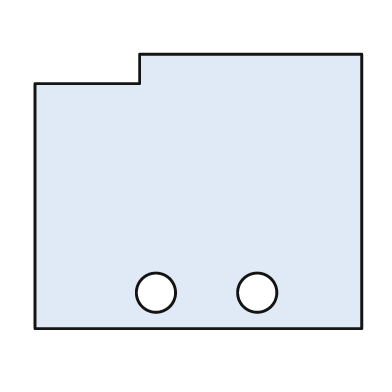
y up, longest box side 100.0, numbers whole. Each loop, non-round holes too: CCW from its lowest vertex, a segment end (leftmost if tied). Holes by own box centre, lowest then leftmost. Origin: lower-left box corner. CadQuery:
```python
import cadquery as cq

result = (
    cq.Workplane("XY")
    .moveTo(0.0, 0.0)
    .lineTo(100.0, 0.0)
    .lineTo(100.0, 84.0)
    .lineTo(32.0, 84.0)
    .lineTo(32.0, 75.0)
    .lineTo(0.0, 75.0)
    .close()
    .moveTo(37.0, 11.0)
    .circle(6.0)
    .moveTo(68.0, 11.0)
    .circle(6.0)
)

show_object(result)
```